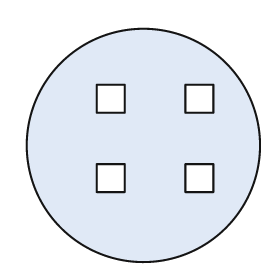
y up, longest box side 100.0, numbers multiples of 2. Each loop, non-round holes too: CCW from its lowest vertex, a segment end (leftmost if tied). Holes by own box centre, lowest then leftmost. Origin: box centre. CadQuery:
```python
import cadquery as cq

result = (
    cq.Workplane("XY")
    .moveTo(0.0, 0.0)
    .circle(50.0)
    .moveTo(-20.0, -20.0)
    .lineTo(-8.0, -20.0)
    .lineTo(-8.0, -8.0)
    .lineTo(-20.0, -8.0)
    .close()
    .moveTo(18.0, -20.0)
    .lineTo(30.0, -20.0)
    .lineTo(30.0, -8.0)
    .lineTo(18.0, -8.0)
    .close()
    .moveTo(-20.0, 14.0)
    .lineTo(-8.0, 14.0)
    .lineTo(-8.0, 26.0)
    .lineTo(-20.0, 26.0)
    .close()
    .moveTo(18.0, 14.0)
    .lineTo(30.0, 14.0)
    .lineTo(30.0, 26.0)
    .lineTo(18.0, 26.0)
    .close()
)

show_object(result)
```